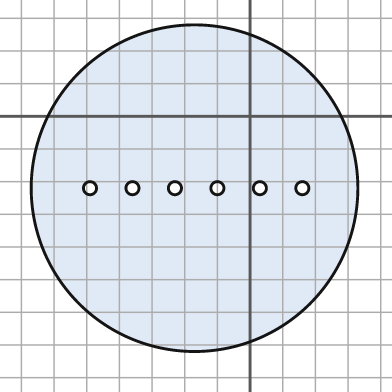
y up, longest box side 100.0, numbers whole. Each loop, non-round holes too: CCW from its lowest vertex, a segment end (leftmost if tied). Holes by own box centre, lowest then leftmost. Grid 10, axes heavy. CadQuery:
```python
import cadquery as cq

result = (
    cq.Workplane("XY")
    .moveTo(-17.0, -22.0)
    .circle(50.0)
    .moveTo(-49.0, -22.0)
    .circle(2.0)
    .moveTo(-36.0, -22.0)
    .circle(2.0)
    .moveTo(-23.0, -22.0)
    .circle(2.0)
    .moveTo(-10.0, -22.0)
    .circle(2.0)
    .moveTo(3.0, -22.0)
    .circle(2.0)
    .moveTo(16.0, -22.0)
    .circle(2.0)
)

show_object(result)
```